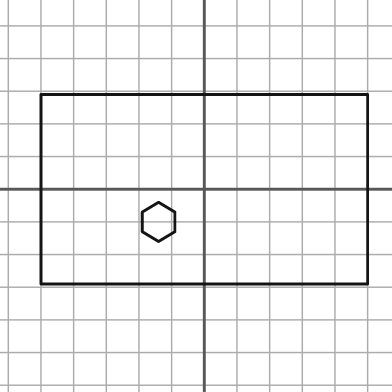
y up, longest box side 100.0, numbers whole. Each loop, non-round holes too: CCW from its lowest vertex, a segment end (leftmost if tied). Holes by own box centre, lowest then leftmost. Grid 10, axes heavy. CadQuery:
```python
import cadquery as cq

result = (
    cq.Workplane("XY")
    .moveTo(-50.0, -29.0)
    .lineTo(50.0, -29.0)
    .lineTo(50.0, 29.0)
    .lineTo(-50.0, 29.0)
    .close()
    .moveTo(-14.0, -16.0)
    .lineTo(-9.0, -13.0)
    .lineTo(-9.0, -7.0)
    .lineTo(-14.0, -4.0)
    .lineTo(-19.0, -7.0)
    .lineTo(-19.0, -13.0)
    .close()
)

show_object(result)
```